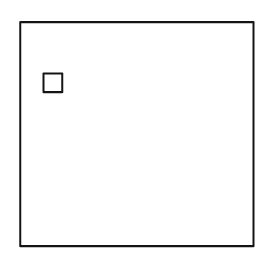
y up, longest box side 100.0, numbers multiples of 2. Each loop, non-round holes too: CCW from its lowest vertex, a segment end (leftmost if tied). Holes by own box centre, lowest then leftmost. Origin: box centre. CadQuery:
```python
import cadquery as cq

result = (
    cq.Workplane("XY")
    .moveTo(-50.0, -48.0)
    .lineTo(50.0, -48.0)
    .lineTo(50.0, 48.0)
    .lineTo(-50.0, 48.0)
    .close()
    .moveTo(-40.0, 18.0)
    .lineTo(-32.0, 18.0)
    .lineTo(-32.0, 26.0)
    .lineTo(-40.0, 26.0)
    .close()
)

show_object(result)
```